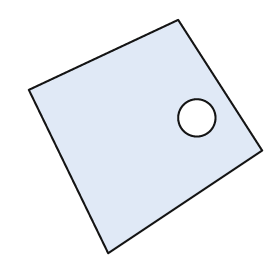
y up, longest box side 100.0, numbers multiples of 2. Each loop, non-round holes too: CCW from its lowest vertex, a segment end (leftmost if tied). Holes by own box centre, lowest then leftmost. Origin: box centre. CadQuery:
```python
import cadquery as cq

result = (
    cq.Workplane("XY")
    .moveTo(-16.0, -50.0)
    .lineTo(50.0, -6.0)
    .lineTo(14.0, 50.0)
    .lineTo(-50.0, 20.0)
    .close()
    .moveTo(22.0, 8.0)
    .circle(8.0)
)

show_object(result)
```